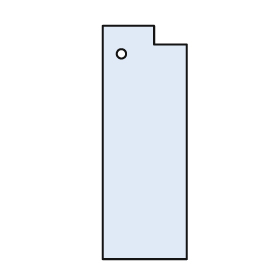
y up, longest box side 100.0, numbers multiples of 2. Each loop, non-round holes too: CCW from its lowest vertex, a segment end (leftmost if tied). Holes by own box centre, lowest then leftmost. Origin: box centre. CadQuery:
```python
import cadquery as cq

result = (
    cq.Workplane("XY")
    .moveTo(-18.0, -50.0)
    .lineTo(18.0, -50.0)
    .lineTo(18.0, 42.0)
    .lineTo(4.0, 42.0)
    .lineTo(4.0, 50.0)
    .lineTo(-18.0, 50.0)
    .close()
    .moveTo(-10.0, 38.0)
    .circle(2.0)
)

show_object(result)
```